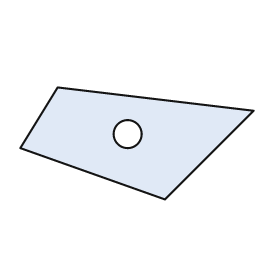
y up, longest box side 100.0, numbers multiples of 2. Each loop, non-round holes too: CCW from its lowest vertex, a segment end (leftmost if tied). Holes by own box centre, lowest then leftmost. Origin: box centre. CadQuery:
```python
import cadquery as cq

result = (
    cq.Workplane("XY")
    .moveTo(12.0, -24.0)
    .lineTo(50.0, 14.0)
    .lineTo(-34.0, 24.0)
    .lineTo(-50.0, -2.0)
    .close()
    .moveTo(-4.0, 4.0)
    .circle(6.0)
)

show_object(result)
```